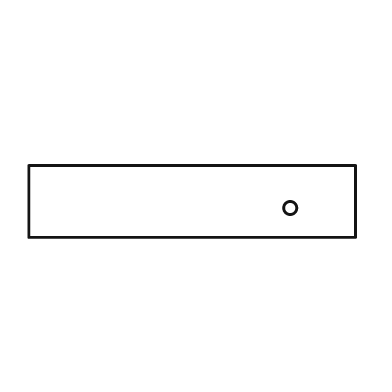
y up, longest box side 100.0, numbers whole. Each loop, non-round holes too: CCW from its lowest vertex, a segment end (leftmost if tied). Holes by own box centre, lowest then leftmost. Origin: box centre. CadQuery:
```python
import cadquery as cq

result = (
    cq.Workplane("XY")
    .moveTo(-50.0, -11.0)
    .lineTo(50.0, -11.0)
    .lineTo(50.0, 11.0)
    .lineTo(-50.0, 11.0)
    .close()
    .moveTo(30.0, -2.0)
    .circle(2.0)
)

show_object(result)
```